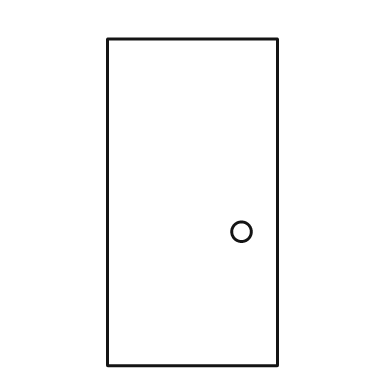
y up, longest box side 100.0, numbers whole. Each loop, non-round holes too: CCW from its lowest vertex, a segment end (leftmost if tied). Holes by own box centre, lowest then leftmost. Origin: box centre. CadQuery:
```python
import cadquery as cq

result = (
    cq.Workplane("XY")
    .moveTo(-26.0, -50.0)
    .lineTo(26.0, -50.0)
    .lineTo(26.0, 50.0)
    .lineTo(-26.0, 50.0)
    .close()
    .moveTo(15.0, -9.0)
    .circle(3.0)
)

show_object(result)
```